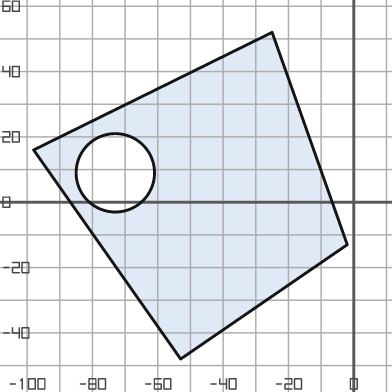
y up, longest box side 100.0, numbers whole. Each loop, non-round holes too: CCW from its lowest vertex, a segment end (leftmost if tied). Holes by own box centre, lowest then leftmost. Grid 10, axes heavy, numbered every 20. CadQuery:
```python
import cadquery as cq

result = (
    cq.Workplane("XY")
    .moveTo(-53.0, -48.0)
    .lineTo(-2.0, -13.0)
    .lineTo(-25.0, 52.0)
    .lineTo(-98.0, 16.0)
    .close()
    .moveTo(-73.0, 9.0)
    .circle(12.0)
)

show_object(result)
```